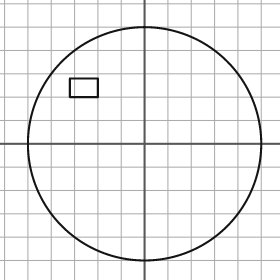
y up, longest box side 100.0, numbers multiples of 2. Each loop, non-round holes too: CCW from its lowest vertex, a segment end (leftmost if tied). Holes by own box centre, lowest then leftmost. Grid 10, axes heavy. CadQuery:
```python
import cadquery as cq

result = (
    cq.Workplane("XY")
    .moveTo(0.0, 0.0)
    .circle(50.0)
    .moveTo(-32.0, 20.0)
    .lineTo(-20.0, 20.0)
    .lineTo(-20.0, 28.0)
    .lineTo(-32.0, 28.0)
    .close()
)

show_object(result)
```